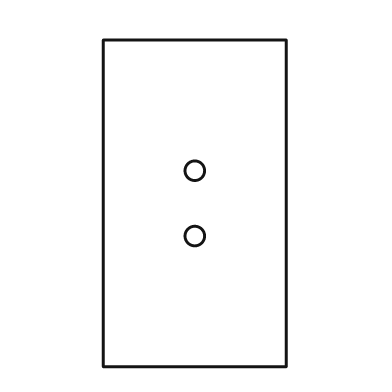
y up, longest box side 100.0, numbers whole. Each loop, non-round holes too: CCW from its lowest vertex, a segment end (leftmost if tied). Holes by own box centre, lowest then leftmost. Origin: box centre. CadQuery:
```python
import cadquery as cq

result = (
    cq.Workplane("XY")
    .moveTo(-28.0, -50.0)
    .lineTo(28.0, -50.0)
    .lineTo(28.0, 50.0)
    .lineTo(-28.0, 50.0)
    .close()
    .moveTo(0.0, -10.0)
    .circle(3.0)
    .moveTo(0.0, 10.0)
    .circle(3.0)
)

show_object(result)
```